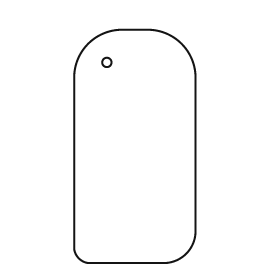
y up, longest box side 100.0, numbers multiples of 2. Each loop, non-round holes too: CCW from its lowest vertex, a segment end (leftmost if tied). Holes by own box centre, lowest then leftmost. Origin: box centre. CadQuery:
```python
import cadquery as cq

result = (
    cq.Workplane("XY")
    .moveTo(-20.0, -50.0)
    .lineTo(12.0, -50.0)
    .threePointArc((22.0, -46.0), (26.0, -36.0))
    .lineTo(26.0, 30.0)
    .threePointArc((20.0, 44.0), (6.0, 50.0))
    .lineTo(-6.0, 50.0)
    .threePointArc((-20.0, 44.0), (-26.0, 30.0))
    .lineTo(-26.0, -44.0)
    .threePointArc((-24.0, -48.0), (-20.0, -50.0))
    .close()
    .moveTo(-12.0, 36.0)
    .circle(2.0)
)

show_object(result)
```